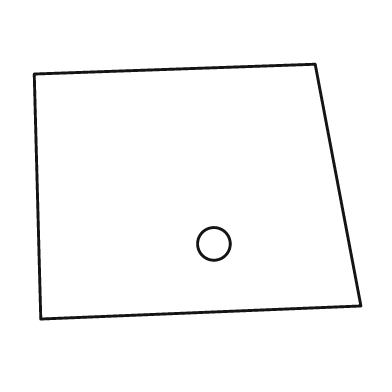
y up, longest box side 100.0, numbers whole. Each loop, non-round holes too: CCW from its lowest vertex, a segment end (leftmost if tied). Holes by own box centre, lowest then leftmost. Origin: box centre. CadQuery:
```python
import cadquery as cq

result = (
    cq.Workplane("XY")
    .moveTo(-48.0, -39.0)
    .lineTo(50.0, -35.0)
    .lineTo(36.0, 39.0)
    .lineTo(-50.0, 36.0)
    .close()
    .moveTo(5.0, -16.0)
    .circle(5.0)
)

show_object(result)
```